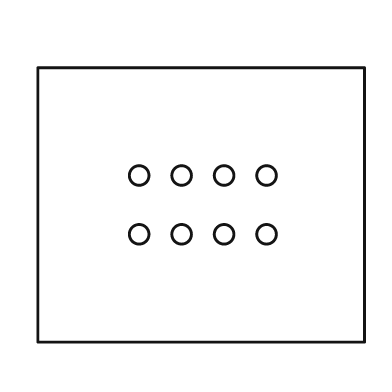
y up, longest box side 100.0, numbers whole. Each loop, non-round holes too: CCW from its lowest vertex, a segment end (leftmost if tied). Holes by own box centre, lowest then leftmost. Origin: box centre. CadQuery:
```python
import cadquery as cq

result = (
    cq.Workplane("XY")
    .moveTo(-50.0, -42.0)
    .lineTo(50.0, -42.0)
    .lineTo(50.0, 42.0)
    .lineTo(-50.0, 42.0)
    .close()
    .moveTo(-19.0, -9.0)
    .circle(3.0)
    .moveTo(-6.0, -9.0)
    .circle(3.0)
    .moveTo(7.0, -9.0)
    .circle(3.0)
    .moveTo(20.0, -9.0)
    .circle(3.0)
    .moveTo(-19.0, 9.0)
    .circle(3.0)
    .moveTo(-6.0, 9.0)
    .circle(3.0)
    .moveTo(7.0, 9.0)
    .circle(3.0)
    .moveTo(20.0, 9.0)
    .circle(3.0)
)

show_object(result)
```